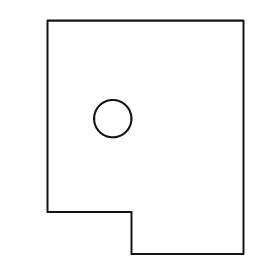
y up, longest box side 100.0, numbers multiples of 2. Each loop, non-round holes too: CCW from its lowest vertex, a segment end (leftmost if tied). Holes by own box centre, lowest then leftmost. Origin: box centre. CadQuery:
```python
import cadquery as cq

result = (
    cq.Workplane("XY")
    .moveTo(-6.0, -50.0)
    .lineTo(42.0, -50.0)
    .lineTo(42.0, 50.0)
    .lineTo(-42.0, 50.0)
    .lineTo(-42.0, -32.0)
    .lineTo(-6.0, -32.0)
    .close()
    .moveTo(-14.0, 8.0)
    .circle(8.0)
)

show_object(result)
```